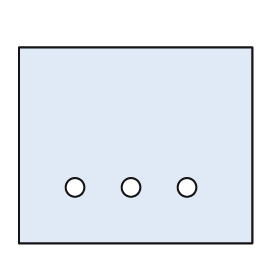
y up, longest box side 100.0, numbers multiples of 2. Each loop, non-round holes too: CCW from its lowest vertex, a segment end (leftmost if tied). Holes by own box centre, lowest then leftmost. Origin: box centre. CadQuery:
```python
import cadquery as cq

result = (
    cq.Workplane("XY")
    .moveTo(-50.0, -42.0)
    .lineTo(50.0, -42.0)
    .lineTo(50.0, 42.0)
    .lineTo(-50.0, 42.0)
    .close()
    .moveTo(-26.0, -18.0)
    .circle(4.0)
    .moveTo(-2.0, -18.0)
    .circle(4.0)
    .moveTo(22.0, -18.0)
    .circle(4.0)
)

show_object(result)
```